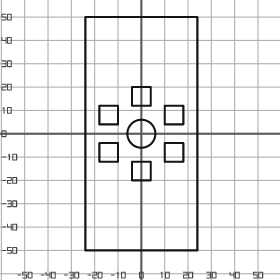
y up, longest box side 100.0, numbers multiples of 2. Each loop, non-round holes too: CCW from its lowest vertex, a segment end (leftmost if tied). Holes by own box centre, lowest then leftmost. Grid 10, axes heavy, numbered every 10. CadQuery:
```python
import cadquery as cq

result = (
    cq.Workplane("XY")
    .moveTo(-24.0, -50.0)
    .lineTo(24.0, -50.0)
    .lineTo(24.0, 50.0)
    .lineTo(-24.0, 50.0)
    .close()
    .moveTo(-4.0, -20.0)
    .lineTo(4.0, -20.0)
    .lineTo(4.0, -12.0)
    .lineTo(-4.0, -12.0)
    .close()
    .moveTo(-18.0, -12.0)
    .lineTo(-10.0, -12.0)
    .lineTo(-10.0, -4.0)
    .lineTo(-18.0, -4.0)
    .close()
    .moveTo(10.0, -12.0)
    .lineTo(18.0, -12.0)
    .lineTo(18.0, -4.0)
    .lineTo(10.0, -4.0)
    .close()
    .moveTo(0.0, 0.0)
    .circle(6.0)
    .moveTo(-18.0, 4.0)
    .lineTo(-10.0, 4.0)
    .lineTo(-10.0, 12.0)
    .lineTo(-18.0, 12.0)
    .close()
    .moveTo(10.0, 4.0)
    .lineTo(18.0, 4.0)
    .lineTo(18.0, 12.0)
    .lineTo(10.0, 12.0)
    .close()
    .moveTo(-4.0, 12.0)
    .lineTo(4.0, 12.0)
    .lineTo(4.0, 20.0)
    .lineTo(-4.0, 20.0)
    .close()
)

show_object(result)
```